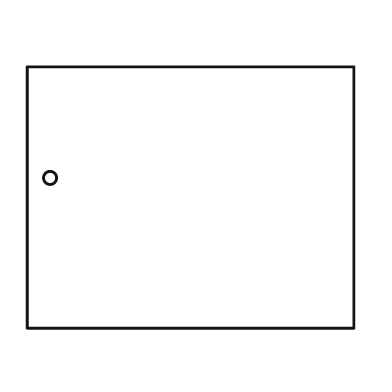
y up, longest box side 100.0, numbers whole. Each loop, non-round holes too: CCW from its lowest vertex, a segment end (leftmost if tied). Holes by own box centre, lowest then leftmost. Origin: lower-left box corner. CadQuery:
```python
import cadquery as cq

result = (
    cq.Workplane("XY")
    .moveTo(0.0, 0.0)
    .lineTo(100.0, 0.0)
    .lineTo(100.0, 80.0)
    .lineTo(0.0, 80.0)
    .close()
    .moveTo(7.0, 46.0)
    .circle(2.0)
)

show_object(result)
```